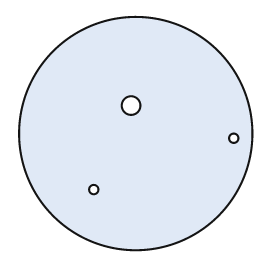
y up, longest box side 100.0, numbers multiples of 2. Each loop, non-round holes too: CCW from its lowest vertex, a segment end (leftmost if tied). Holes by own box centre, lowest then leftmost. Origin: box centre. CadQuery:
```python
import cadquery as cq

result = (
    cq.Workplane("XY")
    .moveTo(0.0, 0.0)
    .circle(50.0)
    .moveTo(-18.0, -24.0)
    .circle(2.0)
    .moveTo(42.0, -2.0)
    .circle(2.0)
    .moveTo(-2.0, 12.0)
    .circle(4.0)
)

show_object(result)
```